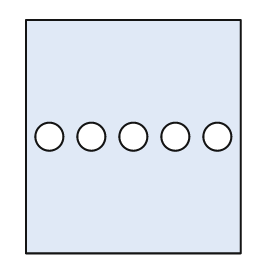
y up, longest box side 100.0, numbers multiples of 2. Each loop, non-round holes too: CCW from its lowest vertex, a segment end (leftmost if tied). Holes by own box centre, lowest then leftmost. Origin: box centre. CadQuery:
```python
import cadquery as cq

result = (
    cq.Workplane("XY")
    .moveTo(-46.0, -50.0)
    .lineTo(46.0, -50.0)
    .lineTo(46.0, 50.0)
    .lineTo(-46.0, 50.0)
    .close()
    .moveTo(-36.0, 0.0)
    .circle(6.0)
    .moveTo(-18.0, 0.0)
    .circle(6.0)
    .moveTo(0.0, 0.0)
    .circle(6.0)
    .moveTo(18.0, 0.0)
    .circle(6.0)
    .moveTo(36.0, 0.0)
    .circle(6.0)
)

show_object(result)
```